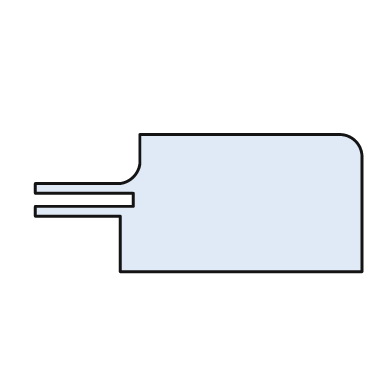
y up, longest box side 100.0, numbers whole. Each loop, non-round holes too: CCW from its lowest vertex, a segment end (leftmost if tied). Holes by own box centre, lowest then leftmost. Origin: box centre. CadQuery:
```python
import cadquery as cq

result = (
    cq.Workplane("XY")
    .moveTo(-24.0, -21.0)
    .lineTo(50.0, -21.0)
    .lineTo(50.0, 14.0)
    .threePointArc((48.0, 19.0), (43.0, 21.0))
    .lineTo(-18.0, 21.0)
    .lineTo(-18.0, 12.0)
    .threePointArc((-20.0, 8.0), (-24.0, 6.0))
    .lineTo(-50.0, 6.0)
    .lineTo(-50.0, 3.0)
    .lineTo(-20.0, 3.0)
    .lineTo(-20.0, -1.0)
    .lineTo(-50.0, -1.0)
    .lineTo(-50.0, -4.0)
    .lineTo(-24.0, -4.0)
    .close()
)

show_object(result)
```